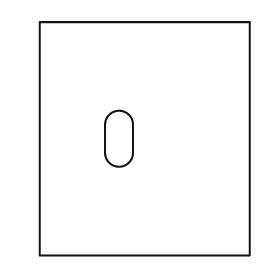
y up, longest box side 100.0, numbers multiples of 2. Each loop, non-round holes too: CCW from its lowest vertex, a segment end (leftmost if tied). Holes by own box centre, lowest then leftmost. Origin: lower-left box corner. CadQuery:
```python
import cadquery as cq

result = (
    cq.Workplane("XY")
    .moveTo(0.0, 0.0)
    .lineTo(90.0, 0.0)
    .lineTo(90.0, 100.0)
    .lineTo(0.0, 100.0)
    .close()
    .moveTo(28.0, 44.0)
    .threePointArc((34.0, 38.0), (40.0, 44.0))
    .lineTo(40.0, 56.0)
    .threePointArc((34.0, 62.0), (28.0, 56.0))
    .close()
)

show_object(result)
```